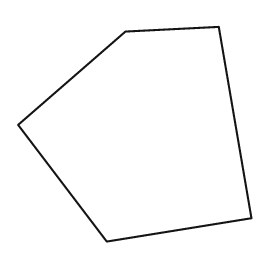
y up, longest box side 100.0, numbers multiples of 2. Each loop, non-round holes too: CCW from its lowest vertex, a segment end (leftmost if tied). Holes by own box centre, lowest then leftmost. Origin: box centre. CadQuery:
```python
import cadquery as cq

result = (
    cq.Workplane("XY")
    .moveTo(-12.0, -46.0)
    .lineTo(50.0, -36.0)
    .lineTo(36.0, 46.0)
    .lineTo(-4.0, 44.0)
    .lineTo(-50.0, 4.0)
    .close()
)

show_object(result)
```